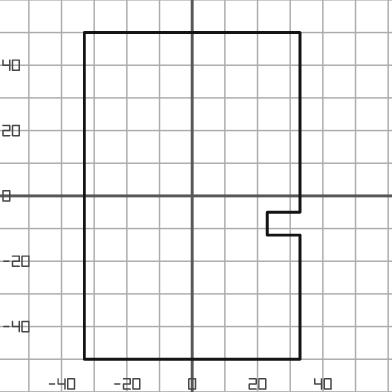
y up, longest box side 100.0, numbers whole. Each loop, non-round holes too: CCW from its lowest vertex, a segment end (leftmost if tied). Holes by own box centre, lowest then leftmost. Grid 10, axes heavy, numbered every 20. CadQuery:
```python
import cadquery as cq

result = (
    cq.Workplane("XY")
    .moveTo(-33.0, -50.0)
    .lineTo(33.0, -50.0)
    .lineTo(33.0, -12.0)
    .lineTo(23.0, -12.0)
    .lineTo(23.0, -5.0)
    .lineTo(33.0, -5.0)
    .lineTo(33.0, 50.0)
    .lineTo(-33.0, 50.0)
    .close()
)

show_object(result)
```